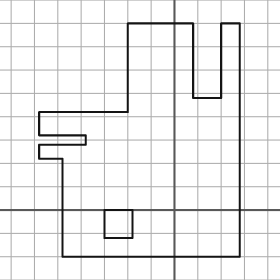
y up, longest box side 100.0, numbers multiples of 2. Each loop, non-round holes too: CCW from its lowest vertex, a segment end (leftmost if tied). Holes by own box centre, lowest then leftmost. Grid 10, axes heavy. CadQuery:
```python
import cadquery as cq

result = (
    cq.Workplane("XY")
    .moveTo(-48.0, -20.0)
    .lineTo(28.0, -20.0)
    .lineTo(28.0, 80.0)
    .lineTo(20.0, 80.0)
    .lineTo(20.0, 48.0)
    .lineTo(8.0, 48.0)
    .lineTo(8.0, 80.0)
    .lineTo(-20.0, 80.0)
    .lineTo(-20.0, 42.0)
    .lineTo(-58.0, 42.0)
    .lineTo(-58.0, 32.0)
    .lineTo(-38.0, 32.0)
    .lineTo(-38.0, 28.0)
    .lineTo(-58.0, 28.0)
    .lineTo(-58.0, 22.0)
    .lineTo(-48.0, 22.0)
    .close()
    .moveTo(-30.0, -12.0)
    .lineTo(-18.0, -12.0)
    .lineTo(-18.0, 0.0)
    .lineTo(-30.0, 0.0)
    .close()
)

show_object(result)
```